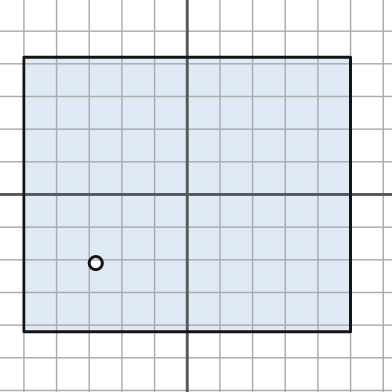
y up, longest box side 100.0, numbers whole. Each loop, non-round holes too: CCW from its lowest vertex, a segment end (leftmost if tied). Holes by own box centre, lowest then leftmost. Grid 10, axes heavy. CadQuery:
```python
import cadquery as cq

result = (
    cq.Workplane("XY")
    .moveTo(-50.0, -42.0)
    .lineTo(50.0, -42.0)
    .lineTo(50.0, 42.0)
    .lineTo(-50.0, 42.0)
    .close()
    .moveTo(-28.0, -21.0)
    .circle(2.0)
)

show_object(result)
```